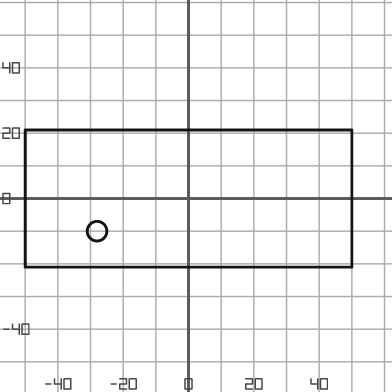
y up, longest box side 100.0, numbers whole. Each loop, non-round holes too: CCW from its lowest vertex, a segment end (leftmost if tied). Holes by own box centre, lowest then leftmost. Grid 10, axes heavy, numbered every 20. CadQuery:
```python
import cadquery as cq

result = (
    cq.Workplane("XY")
    .moveTo(-50.0, -21.0)
    .lineTo(50.0, -21.0)
    .lineTo(50.0, 21.0)
    .lineTo(-50.0, 21.0)
    .close()
    .moveTo(-28.0, -10.0)
    .circle(3.0)
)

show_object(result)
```